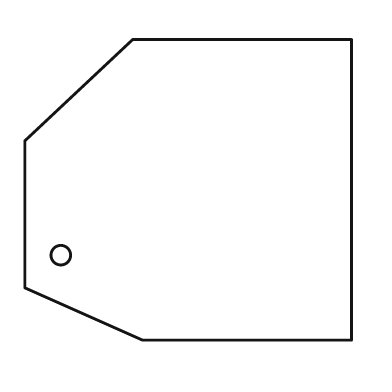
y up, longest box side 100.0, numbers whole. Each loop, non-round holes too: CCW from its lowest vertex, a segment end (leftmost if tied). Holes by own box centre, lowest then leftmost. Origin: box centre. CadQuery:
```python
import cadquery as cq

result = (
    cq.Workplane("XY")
    .moveTo(-14.0, -46.0)
    .lineTo(50.0, -46.0)
    .lineTo(50.0, 46.0)
    .lineTo(-17.0, 46.0)
    .lineTo(-50.0, 15.0)
    .lineTo(-50.0, -30.0)
    .close()
    .moveTo(-39.0, -20.0)
    .circle(3.0)
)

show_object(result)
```